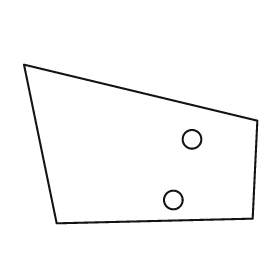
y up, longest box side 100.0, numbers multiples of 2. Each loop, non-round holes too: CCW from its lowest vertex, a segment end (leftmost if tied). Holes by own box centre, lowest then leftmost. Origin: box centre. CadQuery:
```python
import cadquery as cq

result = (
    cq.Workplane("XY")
    .moveTo(-36.0, -34.0)
    .lineTo(48.0, -32.0)
    .lineTo(50.0, 10.0)
    .lineTo(-50.0, 34.0)
    .close()
    .moveTo(14.0, -24.0)
    .circle(4.0)
    .moveTo(22.0, 2.0)
    .circle(4.0)
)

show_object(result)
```